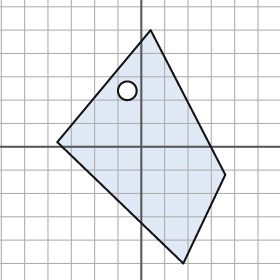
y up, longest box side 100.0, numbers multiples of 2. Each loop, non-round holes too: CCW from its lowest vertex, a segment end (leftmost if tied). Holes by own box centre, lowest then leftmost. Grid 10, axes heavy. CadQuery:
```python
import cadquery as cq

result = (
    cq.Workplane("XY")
    .moveTo(18.0, -50.0)
    .lineTo(36.0, -12.0)
    .lineTo(4.0, 50.0)
    .lineTo(-36.0, 2.0)
    .close()
    .moveTo(-6.0, 24.0)
    .circle(4.0)
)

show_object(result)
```